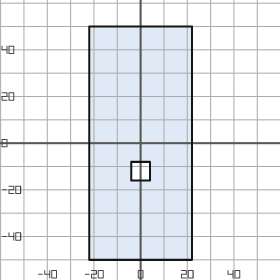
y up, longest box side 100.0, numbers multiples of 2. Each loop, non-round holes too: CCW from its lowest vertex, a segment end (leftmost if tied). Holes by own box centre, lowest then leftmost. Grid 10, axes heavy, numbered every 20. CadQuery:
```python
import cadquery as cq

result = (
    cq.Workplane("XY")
    .moveTo(-22.0, -50.0)
    .lineTo(22.0, -50.0)
    .lineTo(22.0, 50.0)
    .lineTo(-22.0, 50.0)
    .close()
    .moveTo(-4.0, -16.0)
    .lineTo(4.0, -16.0)
    .lineTo(4.0, -8.0)
    .lineTo(-4.0, -8.0)
    .close()
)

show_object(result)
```